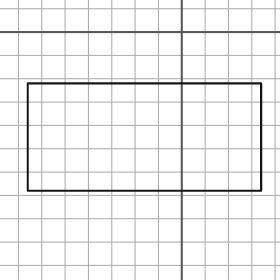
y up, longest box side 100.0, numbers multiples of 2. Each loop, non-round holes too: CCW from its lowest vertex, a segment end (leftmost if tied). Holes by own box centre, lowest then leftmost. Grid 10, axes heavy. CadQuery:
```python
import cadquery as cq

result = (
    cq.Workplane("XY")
    .moveTo(-66.0, -68.0)
    .lineTo(34.0, -68.0)
    .lineTo(34.0, -22.0)
    .lineTo(-66.0, -22.0)
    .close()
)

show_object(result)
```